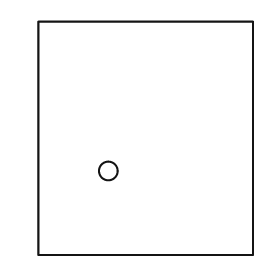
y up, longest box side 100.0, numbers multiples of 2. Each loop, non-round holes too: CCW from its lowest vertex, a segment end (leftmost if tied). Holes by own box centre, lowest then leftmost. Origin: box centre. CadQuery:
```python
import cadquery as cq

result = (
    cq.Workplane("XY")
    .moveTo(-46.0, -50.0)
    .lineTo(46.0, -50.0)
    .lineTo(46.0, 50.0)
    .lineTo(-46.0, 50.0)
    .close()
    .moveTo(-16.0, -14.0)
    .circle(4.0)
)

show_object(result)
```